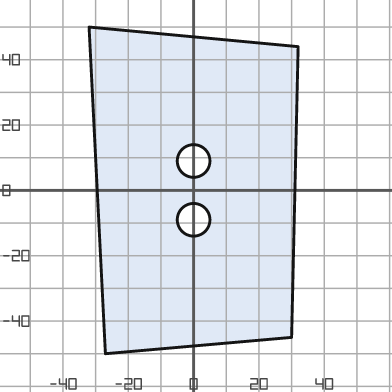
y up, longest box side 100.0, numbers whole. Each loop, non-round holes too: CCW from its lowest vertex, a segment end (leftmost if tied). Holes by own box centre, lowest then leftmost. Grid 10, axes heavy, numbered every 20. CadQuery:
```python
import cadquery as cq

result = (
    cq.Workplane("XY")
    .moveTo(-27.0, -50.0)
    .lineTo(30.0, -45.0)
    .lineTo(32.0, 44.0)
    .lineTo(-32.0, 50.0)
    .close()
    .moveTo(0.0, -9.0)
    .circle(5.0)
    .moveTo(0.0, 9.0)
    .circle(5.0)
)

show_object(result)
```